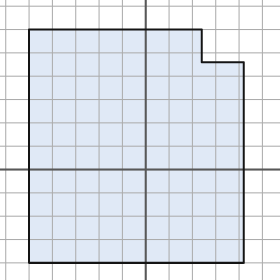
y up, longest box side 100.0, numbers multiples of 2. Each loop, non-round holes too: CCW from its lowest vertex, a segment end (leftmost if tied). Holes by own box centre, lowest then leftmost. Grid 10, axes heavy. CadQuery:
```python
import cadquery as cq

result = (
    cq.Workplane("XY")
    .moveTo(-50.0, -40.0)
    .lineTo(42.0, -40.0)
    .lineTo(42.0, 46.0)
    .lineTo(24.0, 46.0)
    .lineTo(24.0, 60.0)
    .lineTo(-50.0, 60.0)
    .close()
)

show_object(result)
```